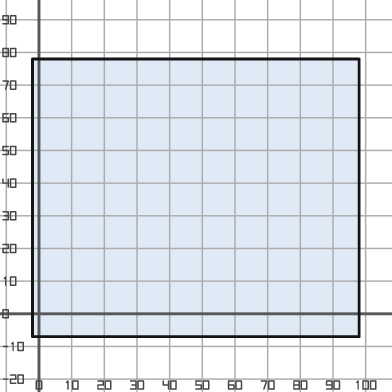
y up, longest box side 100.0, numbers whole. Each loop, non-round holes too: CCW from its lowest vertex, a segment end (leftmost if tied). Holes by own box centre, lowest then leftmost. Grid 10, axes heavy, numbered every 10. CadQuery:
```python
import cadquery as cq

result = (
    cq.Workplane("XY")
    .moveTo(-2.0, -7.0)
    .lineTo(98.0, -7.0)
    .lineTo(98.0, 78.0)
    .lineTo(-2.0, 78.0)
    .close()
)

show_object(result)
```